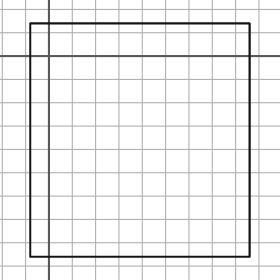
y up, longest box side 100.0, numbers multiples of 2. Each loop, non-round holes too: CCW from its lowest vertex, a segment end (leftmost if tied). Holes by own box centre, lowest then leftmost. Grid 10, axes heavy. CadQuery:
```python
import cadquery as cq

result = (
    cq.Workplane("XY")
    .moveTo(-8.0, -86.0)
    .lineTo(86.0, -86.0)
    .lineTo(86.0, 14.0)
    .lineTo(-8.0, 14.0)
    .close()
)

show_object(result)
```